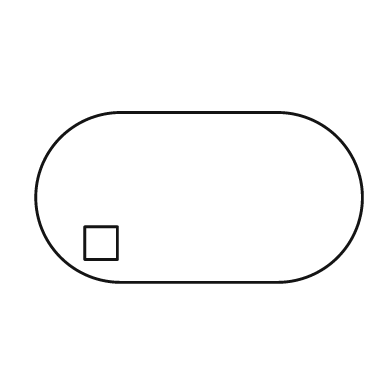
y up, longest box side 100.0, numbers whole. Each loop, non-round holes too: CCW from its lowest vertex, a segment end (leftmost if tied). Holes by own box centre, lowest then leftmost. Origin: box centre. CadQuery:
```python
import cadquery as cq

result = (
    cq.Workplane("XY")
    .moveTo(-24.0, -26.0)
    .lineTo(24.0, -26.0)
    .threePointArc((50.0, 0.0), (24.0, 26.0))
    .lineTo(-24.0, 26.0)
    .threePointArc((-50.0, 0.0), (-24.0, -26.0))
    .close()
    .moveTo(-35.0, -19.0)
    .lineTo(-25.0, -19.0)
    .lineTo(-25.0, -9.0)
    .lineTo(-35.0, -9.0)
    .close()
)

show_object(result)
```